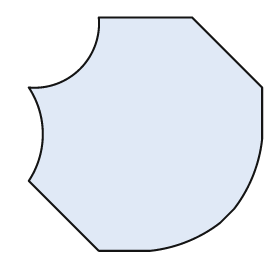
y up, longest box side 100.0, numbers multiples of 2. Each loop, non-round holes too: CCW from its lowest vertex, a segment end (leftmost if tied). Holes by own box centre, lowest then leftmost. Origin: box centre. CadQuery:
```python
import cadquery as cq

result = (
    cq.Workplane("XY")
    .moveTo(-20.0, -50.0)
    .lineTo(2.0, -50.0)
    .threePointArc((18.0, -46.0), (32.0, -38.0))
    .lineTo(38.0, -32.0)
    .threePointArc((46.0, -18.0), (50.0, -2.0))
    .lineTo(50.0, 20.0)
    .lineTo(20.0, 50.0)
    .lineTo(-20.0, 50.0)
    .threePointArc((-28.0, 28.0), (-50.0, 20.0))
    .threePointArc((-44.0, 0.0), (-50.0, -20.0))
    .close()
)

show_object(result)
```